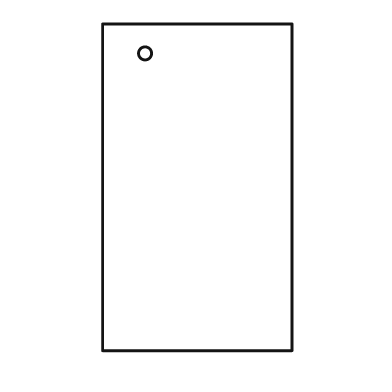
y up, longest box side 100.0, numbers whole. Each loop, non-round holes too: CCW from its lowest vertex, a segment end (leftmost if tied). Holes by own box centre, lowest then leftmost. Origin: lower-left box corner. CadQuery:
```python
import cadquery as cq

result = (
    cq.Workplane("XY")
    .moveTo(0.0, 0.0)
    .lineTo(58.0, 0.0)
    .lineTo(58.0, 100.0)
    .lineTo(0.0, 100.0)
    .close()
    .moveTo(13.0, 91.0)
    .circle(2.0)
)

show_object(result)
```